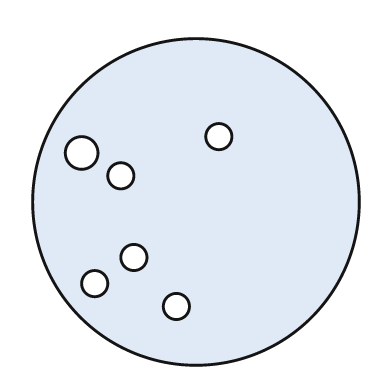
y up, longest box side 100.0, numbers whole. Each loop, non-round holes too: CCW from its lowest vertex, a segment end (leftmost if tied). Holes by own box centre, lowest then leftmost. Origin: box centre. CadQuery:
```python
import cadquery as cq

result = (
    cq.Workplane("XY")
    .moveTo(0.0, 0.0)
    .circle(50.0)
    .moveTo(-6.0, -32.0)
    .circle(4.0)
    .moveTo(-31.0, -25.0)
    .circle(4.0)
    .moveTo(-19.0, -17.0)
    .circle(4.0)
    .moveTo(-23.0, 8.0)
    .circle(4.0)
    .moveTo(-35.0, 15.0)
    .circle(5.0)
    .moveTo(7.0, 20.0)
    .circle(4.0)
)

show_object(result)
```